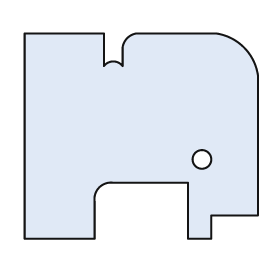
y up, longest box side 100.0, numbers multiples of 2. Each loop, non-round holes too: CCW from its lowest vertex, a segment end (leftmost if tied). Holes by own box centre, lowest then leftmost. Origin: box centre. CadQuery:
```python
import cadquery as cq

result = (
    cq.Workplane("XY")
    .moveTo(-50.0, -44.0)
    .lineTo(-20.0, -44.0)
    .lineTo(-20.0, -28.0)
    .threePointArc((-18.0, -22.0), (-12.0, -20.0))
    .lineTo(20.0, -20.0)
    .lineTo(20.0, -44.0)
    .lineTo(30.0, -44.0)
    .lineTo(30.0, -34.0)
    .lineTo(50.0, -34.0)
    .lineTo(50.0, 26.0)
    .threePointArc((44.0, 38.0), (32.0, 44.0))
    .lineTo(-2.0, 44.0)
    .threePointArc((-6.0, 42.0), (-8.0, 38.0))
    .lineTo(-8.0, 30.0)
    .threePointArc((-12.0, 32.0), (-16.0, 30.0))
    .lineTo(-16.0, 44.0)
    .lineTo(-50.0, 44.0)
    .close()
    .moveTo(26.0, -10.0)
    .circle(4.0)
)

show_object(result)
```